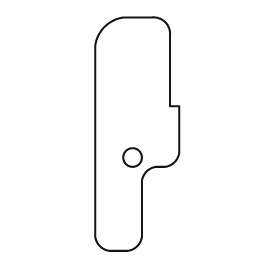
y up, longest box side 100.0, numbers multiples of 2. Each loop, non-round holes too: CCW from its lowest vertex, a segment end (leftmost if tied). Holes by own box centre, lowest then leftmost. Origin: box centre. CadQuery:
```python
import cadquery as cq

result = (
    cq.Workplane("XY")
    .moveTo(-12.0, -50.0)
    .lineTo(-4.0, -50.0)
    .threePointArc((0.0, -48.0), (2.0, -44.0))
    .lineTo(2.0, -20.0)
    .threePointArc((4.0, -16.0), (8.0, -14.0))
    .lineTo(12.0, -14.0)
    .threePointArc((16.0, -12.0), (18.0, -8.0))
    .lineTo(18.0, 12.0)
    .lineTo(14.0, 12.0)
    .lineTo(14.0, 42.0)
    .threePointArc((12.0, 48.0), (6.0, 50.0))
    .lineTo(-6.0, 50.0)
    .threePointArc((-14.0, 46.0), (-18.0, 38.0))
    .lineTo(-18.0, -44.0)
    .threePointArc((-16.0, -48.0), (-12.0, -50.0))
    .close()
    .moveTo(-2.0, -10.0)
    .circle(4.0)
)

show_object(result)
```